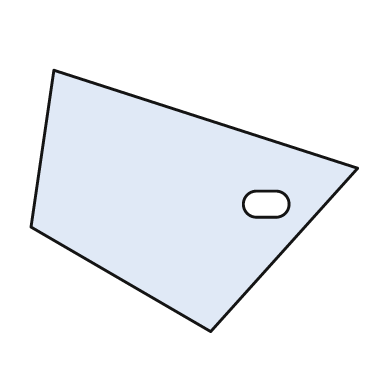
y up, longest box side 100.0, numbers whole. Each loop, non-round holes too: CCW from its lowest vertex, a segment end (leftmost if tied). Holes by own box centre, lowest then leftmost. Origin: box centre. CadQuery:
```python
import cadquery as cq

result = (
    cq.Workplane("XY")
    .moveTo(5.0, -40.0)
    .lineTo(50.0, 10.0)
    .lineTo(-43.0, 40.0)
    .lineTo(-50.0, -8.0)
    .close()
    .moveTo(19.0, -5.0)
    .lineTo(25.0, -5.0)
    .threePointArc((29.0, -1.0), (25.0, 3.0))
    .lineTo(19.0, 3.0)
    .threePointArc((15.0, -1.0), (19.0, -5.0))
    .close()
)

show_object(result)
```